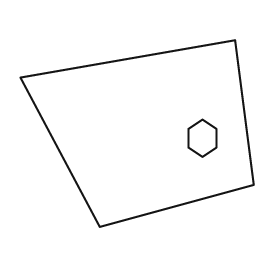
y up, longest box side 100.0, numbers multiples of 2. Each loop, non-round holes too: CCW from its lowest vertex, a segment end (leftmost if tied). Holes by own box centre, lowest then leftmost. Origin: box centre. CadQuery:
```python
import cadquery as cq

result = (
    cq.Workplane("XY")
    .moveTo(-16.0, -40.0)
    .lineTo(50.0, -22.0)
    .lineTo(42.0, 40.0)
    .lineTo(-50.0, 24.0)
    .close()
    .moveTo(28.0, -10.0)
    .lineTo(34.0, -6.0)
    .lineTo(34.0, 2.0)
    .lineTo(28.0, 6.0)
    .lineTo(22.0, 2.0)
    .lineTo(22.0, -6.0)
    .close()
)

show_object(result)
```